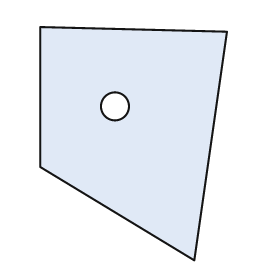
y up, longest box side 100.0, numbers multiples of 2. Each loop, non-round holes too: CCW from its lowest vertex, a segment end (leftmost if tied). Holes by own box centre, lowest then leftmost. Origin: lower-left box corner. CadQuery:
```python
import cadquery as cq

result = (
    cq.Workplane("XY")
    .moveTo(66.0, 0.0)
    .lineTo(80.0, 98.0)
    .lineTo(0.0, 100.0)
    .lineTo(0.0, 40.0)
    .close()
    .moveTo(32.0, 66.0)
    .circle(6.0)
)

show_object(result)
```